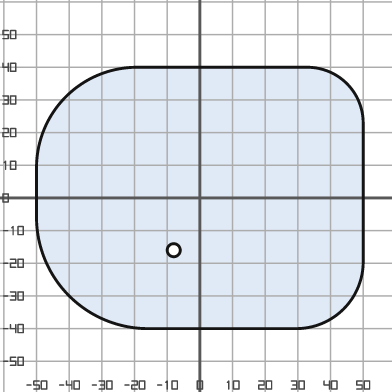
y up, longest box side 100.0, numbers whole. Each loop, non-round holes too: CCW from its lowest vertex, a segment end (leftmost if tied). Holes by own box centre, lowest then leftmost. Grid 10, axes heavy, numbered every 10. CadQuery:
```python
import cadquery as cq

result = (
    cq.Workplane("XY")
    .moveTo(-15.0, -40.0)
    .lineTo(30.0, -40.0)
    .threePointArc((44.0, -34.0), (50.0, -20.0))
    .lineTo(50.0, 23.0)
    .threePointArc((45.0, 35.0), (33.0, 40.0))
    .lineTo(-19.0, 40.0)
    .threePointArc((-41.0, 31.0), (-50.0, 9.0))
    .lineTo(-50.0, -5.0)
    .threePointArc((-40.0, -30.0), (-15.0, -40.0))
    .close()
    .moveTo(-8.0, -16.0)
    .circle(2.0)
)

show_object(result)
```